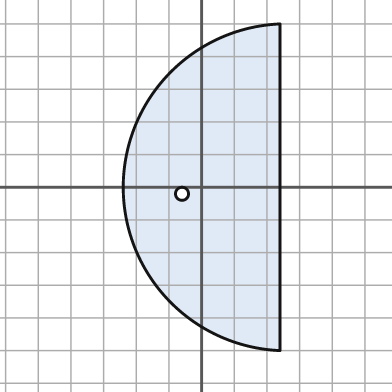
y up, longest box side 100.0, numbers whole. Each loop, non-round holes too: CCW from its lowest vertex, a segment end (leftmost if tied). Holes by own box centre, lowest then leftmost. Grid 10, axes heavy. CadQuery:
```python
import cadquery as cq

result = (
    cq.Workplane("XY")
    .moveTo(24.0, -50.0)
    .lineTo(24.0, 50.0)
    .threePointArc((-24.0, 0.0), (24.0, -50.0))
    .close()
    .moveTo(-6.0, -2.0)
    .circle(2.0)
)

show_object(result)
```